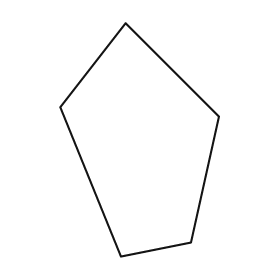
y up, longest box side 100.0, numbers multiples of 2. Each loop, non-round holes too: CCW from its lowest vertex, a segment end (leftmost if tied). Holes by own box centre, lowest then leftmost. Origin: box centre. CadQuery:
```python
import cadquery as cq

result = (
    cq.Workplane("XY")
    .moveTo(-8.0, -50.0)
    .lineTo(22.0, -44.0)
    .lineTo(34.0, 10.0)
    .lineTo(-6.0, 50.0)
    .lineTo(-34.0, 14.0)
    .close()
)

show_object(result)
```